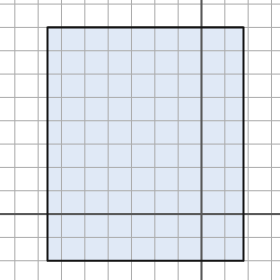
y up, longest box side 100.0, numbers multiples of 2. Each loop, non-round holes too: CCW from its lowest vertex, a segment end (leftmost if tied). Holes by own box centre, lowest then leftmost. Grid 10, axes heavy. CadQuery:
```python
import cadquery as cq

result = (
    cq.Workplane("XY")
    .moveTo(-66.0, -20.0)
    .lineTo(18.0, -20.0)
    .lineTo(18.0, 80.0)
    .lineTo(-66.0, 80.0)
    .close()
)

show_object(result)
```